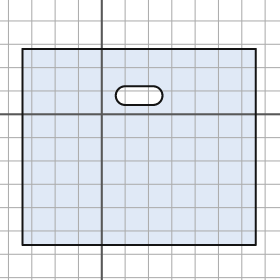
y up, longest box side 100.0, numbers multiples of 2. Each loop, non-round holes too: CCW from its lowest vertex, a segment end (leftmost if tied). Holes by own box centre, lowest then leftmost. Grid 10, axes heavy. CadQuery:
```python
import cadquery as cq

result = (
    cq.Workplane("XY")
    .moveTo(-34.0, -56.0)
    .lineTo(66.0, -56.0)
    .lineTo(66.0, 28.0)
    .lineTo(-34.0, 28.0)
    .close()
    .moveTo(10.0, 4.0)
    .lineTo(22.0, 4.0)
    .threePointArc((26.0, 8.0), (22.0, 12.0))
    .lineTo(10.0, 12.0)
    .threePointArc((6.0, 8.0), (10.0, 4.0))
    .close()
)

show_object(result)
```